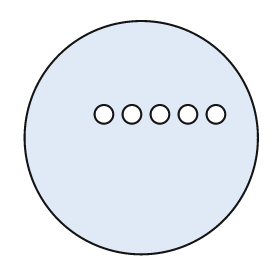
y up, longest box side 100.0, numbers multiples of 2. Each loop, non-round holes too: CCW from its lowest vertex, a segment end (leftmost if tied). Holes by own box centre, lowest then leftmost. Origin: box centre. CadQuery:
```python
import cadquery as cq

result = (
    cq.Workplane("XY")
    .moveTo(0.0, 0.0)
    .circle(50.0)
    .moveTo(-16.0, 10.0)
    .circle(4.0)
    .moveTo(-4.0, 10.0)
    .circle(4.0)
    .moveTo(8.0, 10.0)
    .circle(4.0)
    .moveTo(20.0, 10.0)
    .circle(4.0)
    .moveTo(32.0, 10.0)
    .circle(4.0)
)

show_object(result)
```